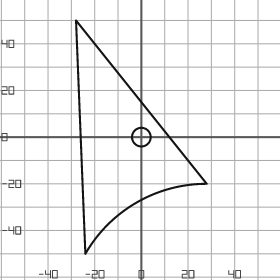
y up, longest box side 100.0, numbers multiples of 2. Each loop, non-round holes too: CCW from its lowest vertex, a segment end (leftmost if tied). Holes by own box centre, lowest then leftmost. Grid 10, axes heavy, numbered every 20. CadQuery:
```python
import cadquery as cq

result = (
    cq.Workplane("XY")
    .moveTo(-24.0, -50.0)
    .threePointArc((-2.0, -28.0), (28.0, -20.0))
    .lineTo(-28.0, 50.0)
    .close()
    .moveTo(0.0, 0.0)
    .circle(4.0)
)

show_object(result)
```